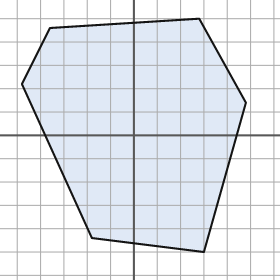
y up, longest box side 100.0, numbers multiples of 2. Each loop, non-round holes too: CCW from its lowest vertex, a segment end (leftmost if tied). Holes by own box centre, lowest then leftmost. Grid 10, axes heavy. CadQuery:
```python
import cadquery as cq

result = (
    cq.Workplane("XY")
    .moveTo(30.0, -50.0)
    .lineTo(48.0, 14.0)
    .lineTo(28.0, 50.0)
    .lineTo(-36.0, 46.0)
    .lineTo(-48.0, 22.0)
    .lineTo(-18.0, -44.0)
    .close()
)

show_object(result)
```